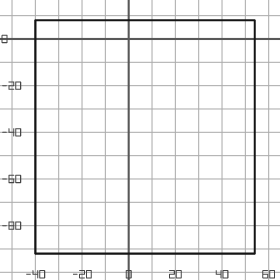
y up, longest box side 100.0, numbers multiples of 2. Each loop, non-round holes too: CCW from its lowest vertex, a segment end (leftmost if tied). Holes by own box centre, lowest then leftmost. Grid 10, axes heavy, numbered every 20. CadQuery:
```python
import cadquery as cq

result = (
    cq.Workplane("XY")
    .moveTo(-40.0, -92.0)
    .lineTo(54.0, -92.0)
    .lineTo(54.0, 8.0)
    .lineTo(-40.0, 8.0)
    .close()
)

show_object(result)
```